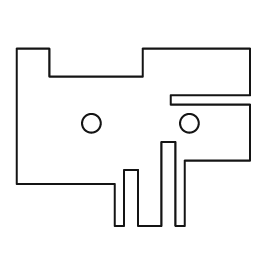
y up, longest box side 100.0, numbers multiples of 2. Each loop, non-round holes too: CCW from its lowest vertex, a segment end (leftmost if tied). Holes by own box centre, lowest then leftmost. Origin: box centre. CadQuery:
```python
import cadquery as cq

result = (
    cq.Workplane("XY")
    .moveTo(-8.0, -38.0)
    .lineTo(-4.0, -38.0)
    .lineTo(-4.0, -14.0)
    .lineTo(2.0, -14.0)
    .lineTo(2.0, -38.0)
    .lineTo(12.0, -38.0)
    .lineTo(12.0, -2.0)
    .lineTo(18.0, -2.0)
    .lineTo(18.0, -38.0)
    .lineTo(22.0, -38.0)
    .lineTo(22.0, -10.0)
    .lineTo(50.0, -10.0)
    .lineTo(50.0, 14.0)
    .lineTo(16.0, 14.0)
    .lineTo(16.0, 18.0)
    .lineTo(50.0, 18.0)
    .lineTo(50.0, 38.0)
    .lineTo(4.0, 38.0)
    .lineTo(4.0, 26.0)
    .lineTo(-36.0, 26.0)
    .lineTo(-36.0, 38.0)
    .lineTo(-50.0, 38.0)
    .lineTo(-50.0, -20.0)
    .lineTo(-8.0, -20.0)
    .close()
    .moveTo(-18.0, 6.0)
    .circle(4.0)
    .moveTo(24.0, 6.0)
    .circle(4.0)
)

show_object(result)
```